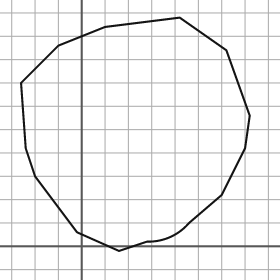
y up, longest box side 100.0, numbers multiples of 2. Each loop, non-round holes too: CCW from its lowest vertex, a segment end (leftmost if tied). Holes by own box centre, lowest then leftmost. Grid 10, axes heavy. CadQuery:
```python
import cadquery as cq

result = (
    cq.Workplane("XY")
    .moveTo(16.0, -2.0)
    .lineTo(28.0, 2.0)
    .threePointArc((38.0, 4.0), (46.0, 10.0))
    .lineTo(60.0, 22.0)
    .lineTo(70.0, 42.0)
    .lineTo(72.0, 56.0)
    .lineTo(62.0, 84.0)
    .lineTo(42.0, 98.0)
    .lineTo(10.0, 94.0)
    .lineTo(-10.0, 86.0)
    .lineTo(-26.0, 70.0)
    .lineTo(-24.0, 42.0)
    .lineTo(-20.0, 30.0)
    .lineTo(-2.0, 6.0)
    .close()
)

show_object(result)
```